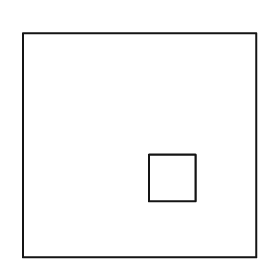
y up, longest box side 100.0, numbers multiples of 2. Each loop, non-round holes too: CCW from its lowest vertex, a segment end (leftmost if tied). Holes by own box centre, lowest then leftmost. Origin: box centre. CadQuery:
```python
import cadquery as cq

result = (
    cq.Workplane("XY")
    .moveTo(-50.0, -48.0)
    .lineTo(50.0, -48.0)
    .lineTo(50.0, 48.0)
    .lineTo(-50.0, 48.0)
    .close()
    .moveTo(4.0, -24.0)
    .lineTo(24.0, -24.0)
    .lineTo(24.0, -4.0)
    .lineTo(4.0, -4.0)
    .close()
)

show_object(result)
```